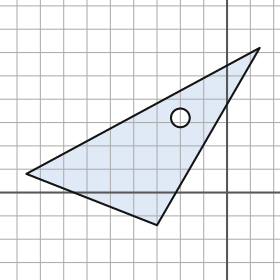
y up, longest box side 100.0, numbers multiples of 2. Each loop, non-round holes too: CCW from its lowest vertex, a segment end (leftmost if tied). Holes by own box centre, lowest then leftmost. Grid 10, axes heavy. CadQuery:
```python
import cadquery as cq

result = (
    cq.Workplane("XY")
    .moveTo(-30.0, -14.0)
    .lineTo(14.0, 62.0)
    .lineTo(-86.0, 8.0)
    .close()
    .moveTo(-20.0, 32.0)
    .circle(4.0)
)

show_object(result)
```